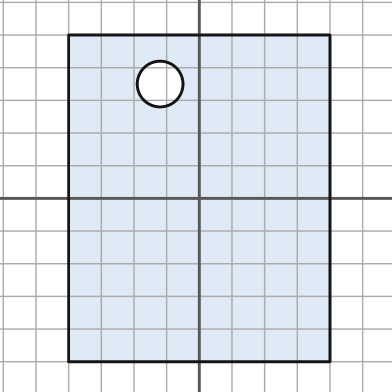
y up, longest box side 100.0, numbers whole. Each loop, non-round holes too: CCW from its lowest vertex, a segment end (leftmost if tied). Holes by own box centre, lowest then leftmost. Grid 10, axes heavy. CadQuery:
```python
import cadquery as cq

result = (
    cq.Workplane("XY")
    .moveTo(-40.0, -50.0)
    .lineTo(40.0, -50.0)
    .lineTo(40.0, 50.0)
    .lineTo(-40.0, 50.0)
    .close()
    .moveTo(-12.0, 35.0)
    .circle(7.0)
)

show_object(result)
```